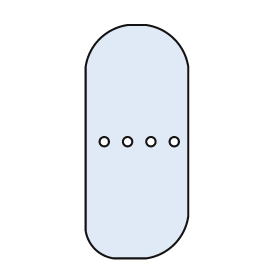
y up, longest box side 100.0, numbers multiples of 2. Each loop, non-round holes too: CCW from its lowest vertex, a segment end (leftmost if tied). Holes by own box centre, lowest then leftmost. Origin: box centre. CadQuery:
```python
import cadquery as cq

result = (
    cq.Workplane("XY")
    .moveTo(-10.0, -50.0)
    .lineTo(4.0, -50.0)
    .threePointArc((16.0, -44.0), (22.0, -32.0))
    .lineTo(22.0, 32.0)
    .threePointArc((16.0, 44.0), (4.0, 50.0))
    .lineTo(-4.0, 50.0)
    .threePointArc((-16.0, 44.0), (-22.0, 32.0))
    .lineTo(-22.0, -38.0)
    .threePointArc((-18.0, -46.0), (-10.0, -50.0))
    .close()
    .moveTo(-14.0, 0.0)
    .circle(2.0)
    .moveTo(-4.0, 0.0)
    .circle(2.0)
    .moveTo(6.0, 0.0)
    .circle(2.0)
    .moveTo(16.0, 0.0)
    .circle(2.0)
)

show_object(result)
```